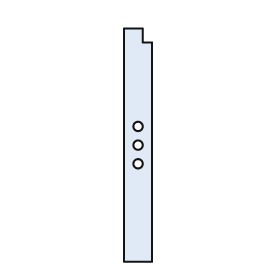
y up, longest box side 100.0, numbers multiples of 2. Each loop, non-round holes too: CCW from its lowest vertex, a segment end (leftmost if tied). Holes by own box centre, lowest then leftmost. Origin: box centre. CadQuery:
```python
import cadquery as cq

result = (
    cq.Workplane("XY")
    .moveTo(-6.0, -50.0)
    .lineTo(6.0, -50.0)
    .lineTo(6.0, 44.0)
    .lineTo(2.0, 44.0)
    .lineTo(2.0, 50.0)
    .lineTo(-6.0, 50.0)
    .close()
    .moveTo(0.0, -8.0)
    .circle(2.0)
    .moveTo(0.0, 0.0)
    .circle(2.0)
    .moveTo(0.0, 8.0)
    .circle(2.0)
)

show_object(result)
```